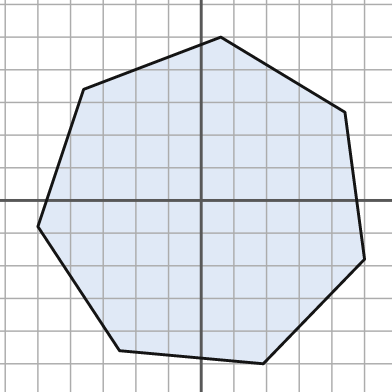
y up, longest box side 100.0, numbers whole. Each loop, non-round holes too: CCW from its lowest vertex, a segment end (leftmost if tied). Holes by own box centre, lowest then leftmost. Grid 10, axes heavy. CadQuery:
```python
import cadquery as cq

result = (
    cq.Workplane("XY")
    .moveTo(19.0, -50.0)
    .lineTo(50.0, -18.0)
    .lineTo(44.0, 27.0)
    .lineTo(6.0, 50.0)
    .lineTo(-36.0, 34.0)
    .lineTo(-50.0, -8.0)
    .lineTo(-25.0, -46.0)
    .close()
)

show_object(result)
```